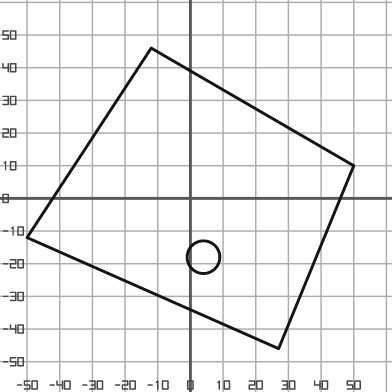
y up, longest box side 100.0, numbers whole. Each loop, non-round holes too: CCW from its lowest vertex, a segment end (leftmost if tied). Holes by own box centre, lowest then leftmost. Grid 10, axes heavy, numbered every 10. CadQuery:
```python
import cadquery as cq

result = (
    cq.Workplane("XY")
    .moveTo(27.0, -46.0)
    .lineTo(50.0, 10.0)
    .lineTo(-12.0, 46.0)
    .lineTo(-50.0, -12.0)
    .close()
    .moveTo(4.0, -18.0)
    .circle(5.0)
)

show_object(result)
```